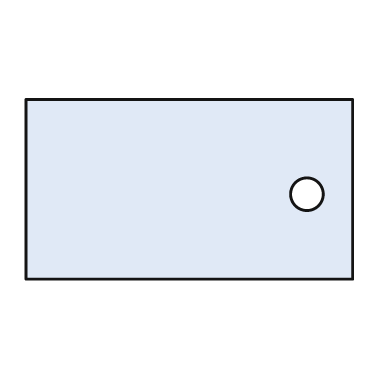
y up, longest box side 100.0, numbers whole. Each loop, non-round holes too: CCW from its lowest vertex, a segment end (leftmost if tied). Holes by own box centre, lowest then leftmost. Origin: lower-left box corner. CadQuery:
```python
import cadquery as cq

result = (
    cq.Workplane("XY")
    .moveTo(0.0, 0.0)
    .lineTo(100.0, 0.0)
    .lineTo(100.0, 55.0)
    .lineTo(0.0, 55.0)
    .close()
    .moveTo(86.0, 26.0)
    .circle(5.0)
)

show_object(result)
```